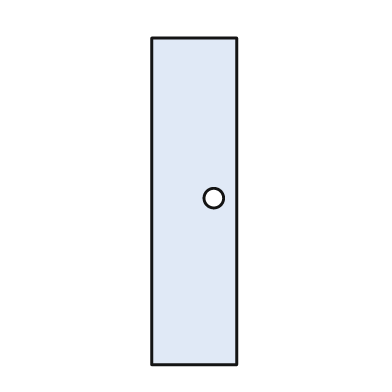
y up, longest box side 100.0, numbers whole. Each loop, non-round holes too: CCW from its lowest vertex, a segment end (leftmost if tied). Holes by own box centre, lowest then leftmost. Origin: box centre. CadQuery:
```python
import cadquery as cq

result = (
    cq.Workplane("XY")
    .moveTo(-13.0, -50.0)
    .lineTo(13.0, -50.0)
    .lineTo(13.0, 50.0)
    .lineTo(-13.0, 50.0)
    .close()
    .moveTo(6.0, 1.0)
    .circle(3.0)
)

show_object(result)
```